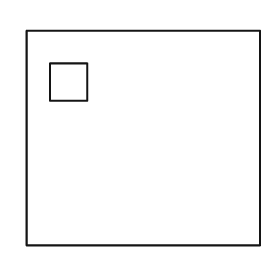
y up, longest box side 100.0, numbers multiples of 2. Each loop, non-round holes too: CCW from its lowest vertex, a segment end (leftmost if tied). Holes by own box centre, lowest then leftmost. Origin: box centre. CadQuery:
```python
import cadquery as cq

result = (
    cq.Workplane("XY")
    .moveTo(-50.0, -46.0)
    .lineTo(50.0, -46.0)
    .lineTo(50.0, 46.0)
    .lineTo(-50.0, 46.0)
    .close()
    .moveTo(-40.0, 16.0)
    .lineTo(-24.0, 16.0)
    .lineTo(-24.0, 32.0)
    .lineTo(-40.0, 32.0)
    .close()
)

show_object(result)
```